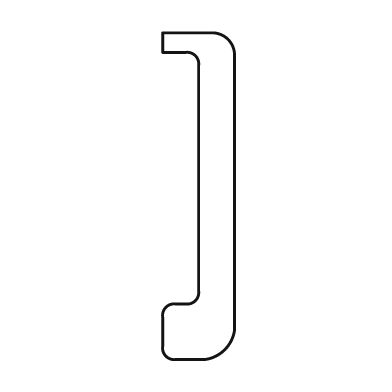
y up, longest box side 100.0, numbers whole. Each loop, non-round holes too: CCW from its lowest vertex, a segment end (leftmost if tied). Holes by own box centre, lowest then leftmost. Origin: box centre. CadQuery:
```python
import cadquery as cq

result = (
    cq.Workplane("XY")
    .moveTo(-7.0, -50.0)
    .lineTo(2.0, -50.0)
    .threePointArc((8.0, -47.0), (11.0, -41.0))
    .lineTo(11.0, 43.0)
    .threePointArc((9.0, 48.0), (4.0, 50.0))
    .lineTo(-11.0, 50.0)
    .lineTo(-11.0, 44.0)
    .lineTo(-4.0, 44.0)
    .threePointArc((-1.0, 43.0), (0.0, 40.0))
    .lineTo(0.0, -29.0)
    .threePointArc((-1.0, -32.0), (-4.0, -33.0))
    .lineTo(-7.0, -33.0)
    .threePointArc((-10.0, -34.0), (-11.0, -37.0))
    .lineTo(-11.0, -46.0)
    .threePointArc((-10.0, -49.0), (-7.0, -50.0))
    .close()
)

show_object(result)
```